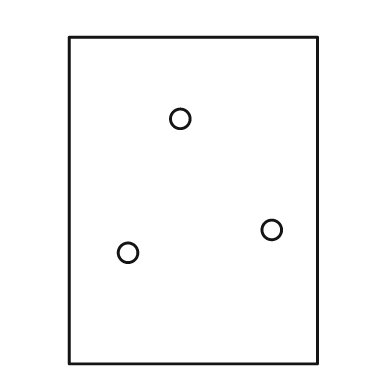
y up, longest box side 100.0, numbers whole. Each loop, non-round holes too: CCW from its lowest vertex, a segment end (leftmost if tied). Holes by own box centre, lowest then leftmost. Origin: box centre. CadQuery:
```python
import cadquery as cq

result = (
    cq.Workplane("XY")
    .moveTo(-38.0, -50.0)
    .lineTo(38.0, -50.0)
    .lineTo(38.0, 50.0)
    .lineTo(-38.0, 50.0)
    .close()
    .moveTo(-20.0, -16.0)
    .circle(3.0)
    .moveTo(24.0, -9.0)
    .circle(3.0)
    .moveTo(-4.0, 25.0)
    .circle(3.0)
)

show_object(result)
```